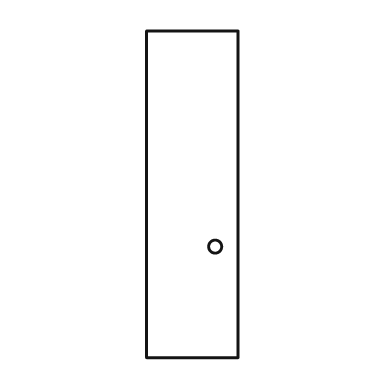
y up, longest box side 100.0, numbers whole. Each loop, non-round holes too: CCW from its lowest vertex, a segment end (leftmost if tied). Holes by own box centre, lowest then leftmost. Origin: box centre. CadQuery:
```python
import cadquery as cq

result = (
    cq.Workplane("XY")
    .moveTo(-14.0, -50.0)
    .lineTo(14.0, -50.0)
    .lineTo(14.0, 50.0)
    .lineTo(-14.0, 50.0)
    .close()
    .moveTo(7.0, -16.0)
    .circle(2.0)
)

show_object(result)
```